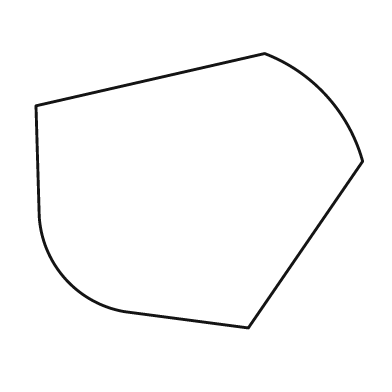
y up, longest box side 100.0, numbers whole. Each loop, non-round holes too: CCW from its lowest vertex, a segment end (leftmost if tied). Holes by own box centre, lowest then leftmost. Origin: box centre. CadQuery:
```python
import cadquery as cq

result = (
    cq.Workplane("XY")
    .moveTo(15.0, -42.0)
    .lineTo(50.0, 9.0)
    .threePointArc((39.0, 29.0), (20.0, 42.0))
    .lineTo(-50.0, 26.0)
    .lineTo(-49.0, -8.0)
    .threePointArc((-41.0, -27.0), (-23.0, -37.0))
    .close()
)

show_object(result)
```